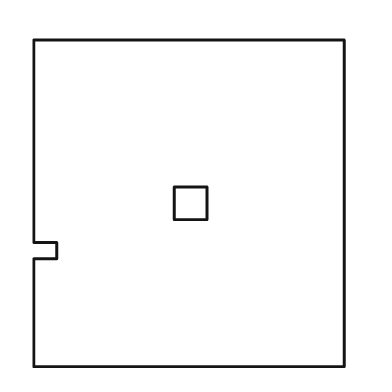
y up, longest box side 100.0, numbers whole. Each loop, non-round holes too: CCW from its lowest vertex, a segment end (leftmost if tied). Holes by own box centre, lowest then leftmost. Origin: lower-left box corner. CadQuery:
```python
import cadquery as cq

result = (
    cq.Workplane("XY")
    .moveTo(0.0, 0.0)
    .lineTo(95.0, 0.0)
    .lineTo(95.0, 100.0)
    .lineTo(0.0, 100.0)
    .lineTo(0.0, 38.0)
    .lineTo(7.0, 38.0)
    .lineTo(7.0, 33.0)
    .lineTo(0.0, 33.0)
    .close()
    .moveTo(43.0, 45.0)
    .lineTo(53.0, 45.0)
    .lineTo(53.0, 55.0)
    .lineTo(43.0, 55.0)
    .close()
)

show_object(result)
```